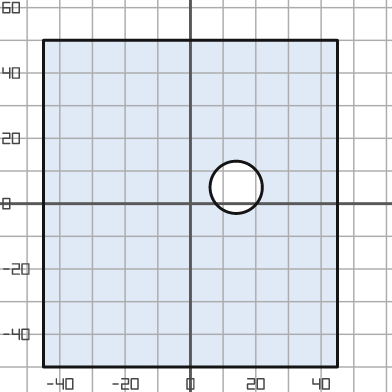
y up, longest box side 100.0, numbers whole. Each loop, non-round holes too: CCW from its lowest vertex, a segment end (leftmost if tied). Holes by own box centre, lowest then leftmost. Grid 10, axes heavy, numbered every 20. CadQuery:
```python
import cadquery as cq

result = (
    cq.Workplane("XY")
    .moveTo(-45.0, -50.0)
    .lineTo(45.0, -50.0)
    .lineTo(45.0, 50.0)
    .lineTo(-45.0, 50.0)
    .close()
    .moveTo(14.0, 5.0)
    .circle(8.0)
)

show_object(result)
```